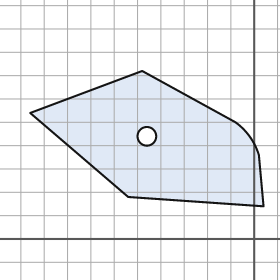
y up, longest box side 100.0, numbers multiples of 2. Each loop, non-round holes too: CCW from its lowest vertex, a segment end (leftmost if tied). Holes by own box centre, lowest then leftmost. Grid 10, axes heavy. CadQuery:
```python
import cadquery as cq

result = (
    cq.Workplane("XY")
    .moveTo(4.0, 14.0)
    .lineTo(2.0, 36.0)
    .threePointArc((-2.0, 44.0), (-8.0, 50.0))
    .lineTo(-48.0, 72.0)
    .lineTo(-96.0, 54.0)
    .lineTo(-54.0, 18.0)
    .close()
    .moveTo(-46.0, 44.0)
    .circle(4.0)
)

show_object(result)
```